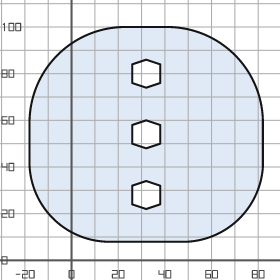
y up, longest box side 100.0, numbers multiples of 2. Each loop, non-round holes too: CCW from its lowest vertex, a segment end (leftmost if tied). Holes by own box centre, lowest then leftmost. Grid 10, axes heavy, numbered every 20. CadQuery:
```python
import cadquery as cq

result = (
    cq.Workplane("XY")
    .moveTo(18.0, 8.0)
    .lineTo(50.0, 8.0)
    .threePointArc((72.0, 18.0), (82.0, 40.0))
    .lineTo(82.0, 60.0)
    .threePointArc((70.0, 88.0), (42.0, 100.0))
    .lineTo(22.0, 100.0)
    .threePointArc((-6.0, 88.0), (-18.0, 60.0))
    .lineTo(-18.0, 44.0)
    .threePointArc((-8.0, 18.0), (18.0, 8.0))
    .close()
    .moveTo(32.0, 22.0)
    .lineTo(38.0, 24.0)
    .lineTo(38.0, 32.0)
    .lineTo(32.0, 34.0)
    .lineTo(26.0, 32.0)
    .lineTo(26.0, 24.0)
    .close()
    .moveTo(32.0, 48.0)
    .lineTo(38.0, 50.0)
    .lineTo(38.0, 58.0)
    .lineTo(32.0, 60.0)
    .lineTo(26.0, 58.0)
    .lineTo(26.0, 50.0)
    .close()
    .moveTo(32.0, 74.0)
    .lineTo(38.0, 76.0)
    .lineTo(38.0, 84.0)
    .lineTo(32.0, 86.0)
    .lineTo(26.0, 84.0)
    .lineTo(26.0, 76.0)
    .close()
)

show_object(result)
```